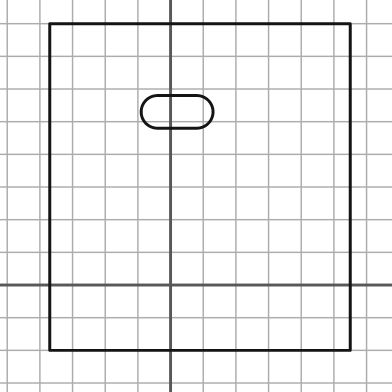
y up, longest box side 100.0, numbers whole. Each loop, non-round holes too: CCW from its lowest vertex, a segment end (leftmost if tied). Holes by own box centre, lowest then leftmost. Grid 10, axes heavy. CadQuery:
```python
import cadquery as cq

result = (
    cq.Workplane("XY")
    .moveTo(-37.0, -20.0)
    .lineTo(55.0, -20.0)
    .lineTo(55.0, 80.0)
    .lineTo(-37.0, 80.0)
    .close()
    .moveTo(-4.0, 48.0)
    .lineTo(8.0, 48.0)
    .threePointArc((13.0, 53.0), (8.0, 58.0))
    .lineTo(-4.0, 58.0)
    .threePointArc((-9.0, 53.0), (-4.0, 48.0))
    .close()
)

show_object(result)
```